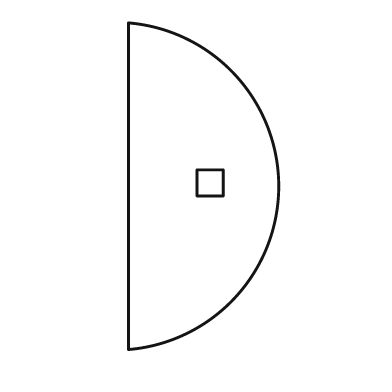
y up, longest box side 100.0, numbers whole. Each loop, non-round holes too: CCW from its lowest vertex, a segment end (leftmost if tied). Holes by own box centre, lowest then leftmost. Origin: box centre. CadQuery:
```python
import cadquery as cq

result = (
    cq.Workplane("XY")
    .moveTo(-23.0, -50.0)
    .threePointArc((23.0, 0.0), (-23.0, 50.0))
    .close()
    .moveTo(-2.0, -3.0)
    .lineTo(6.0, -3.0)
    .lineTo(6.0, 5.0)
    .lineTo(-2.0, 5.0)
    .close()
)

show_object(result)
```